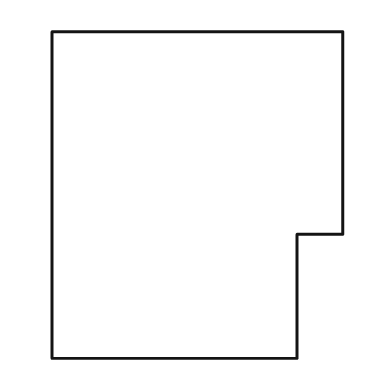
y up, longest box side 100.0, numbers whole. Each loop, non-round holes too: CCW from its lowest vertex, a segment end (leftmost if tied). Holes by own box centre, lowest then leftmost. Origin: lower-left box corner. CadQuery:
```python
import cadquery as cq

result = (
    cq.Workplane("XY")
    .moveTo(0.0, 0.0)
    .lineTo(75.0, 0.0)
    .lineTo(75.0, 38.0)
    .lineTo(89.0, 38.0)
    .lineTo(89.0, 100.0)
    .lineTo(0.0, 100.0)
    .close()
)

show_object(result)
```